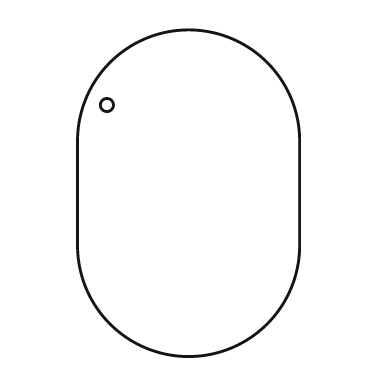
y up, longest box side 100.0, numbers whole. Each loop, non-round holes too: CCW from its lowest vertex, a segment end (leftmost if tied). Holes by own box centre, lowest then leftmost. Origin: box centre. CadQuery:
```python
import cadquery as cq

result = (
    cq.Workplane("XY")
    .moveTo(-34.0, -16.0)
    .threePointArc((0.0, -50.0), (34.0, -16.0))
    .lineTo(34.0, 16.0)
    .threePointArc((0.0, 50.0), (-34.0, 16.0))
    .close()
    .moveTo(-25.0, 27.0)
    .circle(2.0)
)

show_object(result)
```